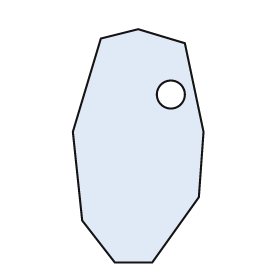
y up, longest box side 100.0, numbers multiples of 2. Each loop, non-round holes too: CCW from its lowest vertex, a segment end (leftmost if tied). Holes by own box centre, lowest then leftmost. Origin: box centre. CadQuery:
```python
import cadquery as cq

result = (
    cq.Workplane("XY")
    .moveTo(-10.0, -50.0)
    .lineTo(6.0, -50.0)
    .lineTo(26.0, -22.0)
    .lineTo(28.0, 6.0)
    .lineTo(20.0, 44.0)
    .lineTo(0.0, 50.0)
    .lineTo(-16.0, 46.0)
    .lineTo(-28.0, 6.0)
    .lineTo(-24.0, -32.0)
    .close()
    .moveTo(14.0, 22.0)
    .circle(6.0)
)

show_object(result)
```